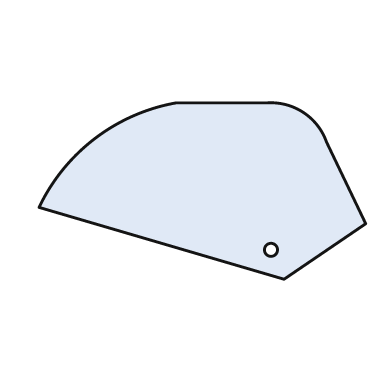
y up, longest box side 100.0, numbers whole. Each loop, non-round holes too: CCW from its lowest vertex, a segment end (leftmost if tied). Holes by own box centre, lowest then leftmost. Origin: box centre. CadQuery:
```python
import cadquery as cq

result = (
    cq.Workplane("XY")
    .moveTo(25.0, -27.0)
    .lineTo(50.0, -10.0)
    .lineTo(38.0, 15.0)
    .threePointArc((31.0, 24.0), (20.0, 27.0))
    .lineTo(-8.0, 27.0)
    .threePointArc((-33.0, 16.0), (-50.0, -5.0))
    .close()
    .moveTo(21.0, -18.0)
    .circle(2.0)
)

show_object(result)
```